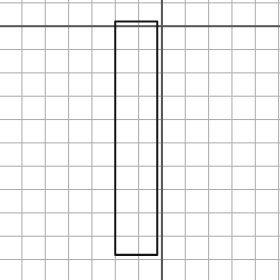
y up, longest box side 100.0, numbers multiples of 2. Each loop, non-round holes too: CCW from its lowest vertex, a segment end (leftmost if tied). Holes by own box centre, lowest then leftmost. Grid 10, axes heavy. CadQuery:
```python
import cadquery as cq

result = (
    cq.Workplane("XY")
    .moveTo(-20.0, -98.0)
    .lineTo(-2.0, -98.0)
    .lineTo(-2.0, 2.0)
    .lineTo(-20.0, 2.0)
    .close()
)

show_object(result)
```